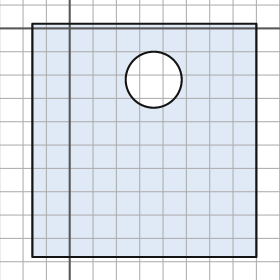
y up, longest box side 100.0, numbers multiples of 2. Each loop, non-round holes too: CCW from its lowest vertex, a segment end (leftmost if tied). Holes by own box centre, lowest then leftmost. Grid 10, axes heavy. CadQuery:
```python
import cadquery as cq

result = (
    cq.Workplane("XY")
    .moveTo(-16.0, -98.0)
    .lineTo(80.0, -98.0)
    .lineTo(80.0, 2.0)
    .lineTo(-16.0, 2.0)
    .close()
    .moveTo(36.0, -22.0)
    .circle(12.0)
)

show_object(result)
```